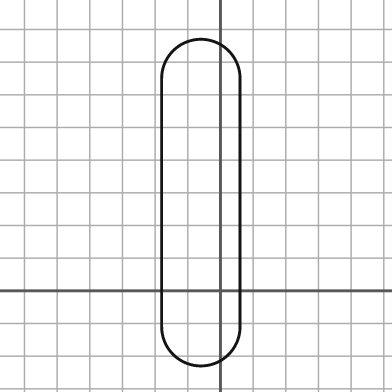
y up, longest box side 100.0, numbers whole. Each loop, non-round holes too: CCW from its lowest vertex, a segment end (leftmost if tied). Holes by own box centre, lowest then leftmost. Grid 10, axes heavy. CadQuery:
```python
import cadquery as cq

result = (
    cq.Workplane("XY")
    .moveTo(-18.0, -11.0)
    .threePointArc((-6.0, -23.0), (6.0, -11.0))
    .lineTo(6.0, 65.0)
    .threePointArc((-6.0, 77.0), (-18.0, 65.0))
    .close()
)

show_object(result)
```